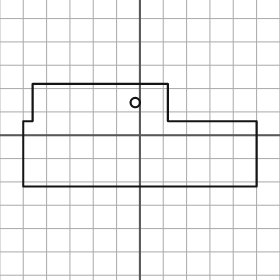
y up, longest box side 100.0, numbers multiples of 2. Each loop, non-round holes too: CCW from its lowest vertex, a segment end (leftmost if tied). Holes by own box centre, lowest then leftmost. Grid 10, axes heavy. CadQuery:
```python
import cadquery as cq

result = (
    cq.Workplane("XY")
    .moveTo(-50.0, -22.0)
    .lineTo(50.0, -22.0)
    .lineTo(50.0, 6.0)
    .lineTo(12.0, 6.0)
    .lineTo(12.0, 22.0)
    .lineTo(-46.0, 22.0)
    .lineTo(-46.0, 6.0)
    .lineTo(-50.0, 6.0)
    .close()
    .moveTo(-2.0, 14.0)
    .circle(2.0)
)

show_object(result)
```